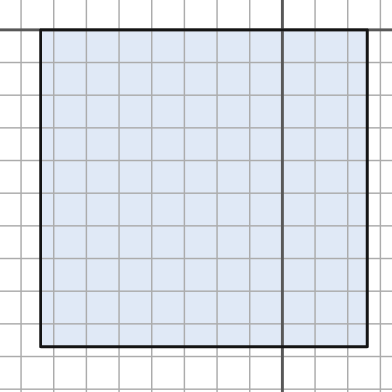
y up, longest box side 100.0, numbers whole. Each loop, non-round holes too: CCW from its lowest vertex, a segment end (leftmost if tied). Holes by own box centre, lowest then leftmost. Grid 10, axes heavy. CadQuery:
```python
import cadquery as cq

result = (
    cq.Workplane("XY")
    .moveTo(-74.0, -97.0)
    .lineTo(26.0, -97.0)
    .lineTo(26.0, 0.0)
    .lineTo(-74.0, 0.0)
    .close()
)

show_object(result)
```